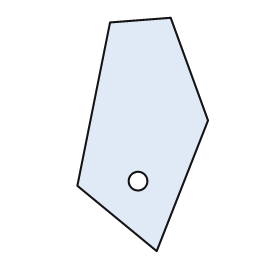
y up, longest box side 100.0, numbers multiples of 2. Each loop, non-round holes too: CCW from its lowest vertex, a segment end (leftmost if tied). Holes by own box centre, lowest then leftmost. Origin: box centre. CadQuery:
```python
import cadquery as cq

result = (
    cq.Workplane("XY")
    .moveTo(6.0, -50.0)
    .lineTo(28.0, 6.0)
    .lineTo(12.0, 50.0)
    .lineTo(-14.0, 48.0)
    .lineTo(-28.0, -22.0)
    .close()
    .moveTo(-2.0, -20.0)
    .circle(4.0)
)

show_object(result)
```